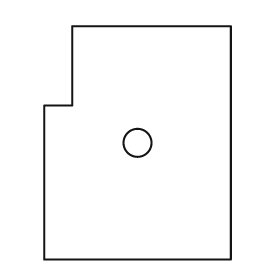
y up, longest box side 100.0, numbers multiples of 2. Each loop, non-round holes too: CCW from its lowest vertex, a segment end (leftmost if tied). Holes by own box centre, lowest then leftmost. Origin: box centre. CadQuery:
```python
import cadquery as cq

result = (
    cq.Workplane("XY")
    .moveTo(-40.0, -50.0)
    .lineTo(40.0, -50.0)
    .lineTo(40.0, 50.0)
    .lineTo(-28.0, 50.0)
    .lineTo(-28.0, 16.0)
    .lineTo(-40.0, 16.0)
    .close()
    .moveTo(0.0, 0.0)
    .circle(6.0)
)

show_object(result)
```